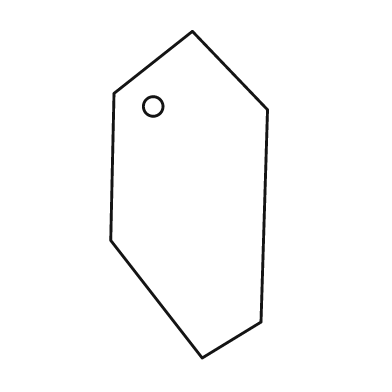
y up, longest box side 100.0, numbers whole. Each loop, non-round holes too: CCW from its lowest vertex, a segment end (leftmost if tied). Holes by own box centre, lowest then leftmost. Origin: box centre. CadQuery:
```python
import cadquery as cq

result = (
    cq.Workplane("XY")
    .moveTo(4.0, -50.0)
    .lineTo(22.0, -39.0)
    .lineTo(24.0, 26.0)
    .lineTo(1.0, 50.0)
    .lineTo(-23.0, 31.0)
    .lineTo(-24.0, -14.0)
    .close()
    .moveTo(-11.0, 27.0)
    .circle(3.0)
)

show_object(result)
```